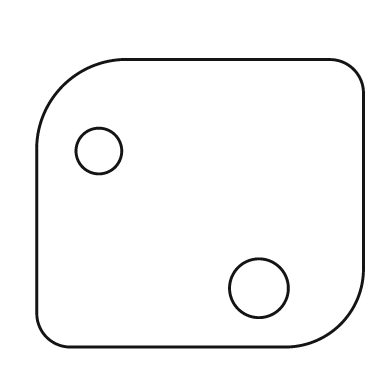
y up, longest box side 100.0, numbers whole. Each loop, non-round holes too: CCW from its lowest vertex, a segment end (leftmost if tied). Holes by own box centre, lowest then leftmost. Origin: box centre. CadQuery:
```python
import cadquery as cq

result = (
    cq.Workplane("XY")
    .moveTo(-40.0, -44.0)
    .lineTo(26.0, -44.0)
    .threePointArc((43.0, -37.0), (50.0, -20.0))
    .lineTo(50.0, 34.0)
    .threePointArc((47.0, 41.0), (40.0, 44.0))
    .lineTo(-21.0, 44.0)
    .threePointArc((-42.0, 36.0), (-50.0, 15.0))
    .lineTo(-50.0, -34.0)
    .threePointArc((-47.0, -41.0), (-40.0, -44.0))
    .close()
    .moveTo(18.0, -26.0)
    .circle(9.0)
    .moveTo(-31.0, 16.0)
    .circle(7.0)
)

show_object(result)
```